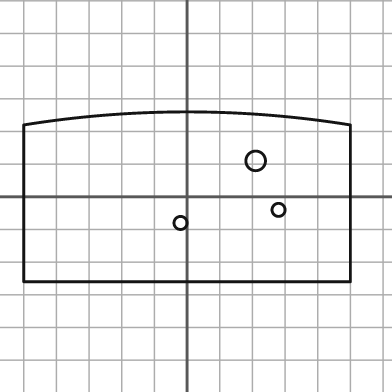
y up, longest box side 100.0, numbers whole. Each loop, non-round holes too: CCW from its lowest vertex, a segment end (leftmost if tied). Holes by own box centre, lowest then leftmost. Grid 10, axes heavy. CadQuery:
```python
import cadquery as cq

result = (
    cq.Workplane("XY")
    .moveTo(-50.0, -26.0)
    .lineTo(50.0, -26.0)
    .lineTo(50.0, 22.0)
    .threePointArc((0.0, 26.0), (-50.0, 22.0))
    .close()
    .moveTo(-2.0, -8.0)
    .circle(2.0)
    .moveTo(28.0, -4.0)
    .circle(2.0)
    .moveTo(21.0, 11.0)
    .circle(3.0)
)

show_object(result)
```